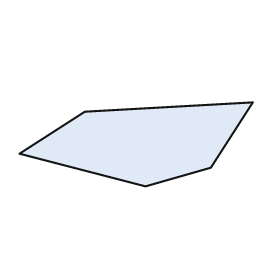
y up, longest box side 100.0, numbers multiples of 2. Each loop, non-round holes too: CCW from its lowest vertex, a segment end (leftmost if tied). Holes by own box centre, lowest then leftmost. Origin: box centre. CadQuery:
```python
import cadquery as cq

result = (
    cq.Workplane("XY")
    .moveTo(4.0, -18.0)
    .lineTo(32.0, -10.0)
    .lineTo(50.0, 18.0)
    .lineTo(-22.0, 14.0)
    .lineTo(-50.0, -4.0)
    .close()
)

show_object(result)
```